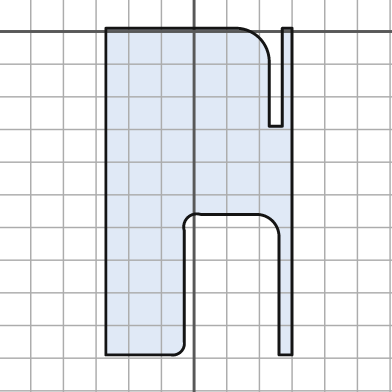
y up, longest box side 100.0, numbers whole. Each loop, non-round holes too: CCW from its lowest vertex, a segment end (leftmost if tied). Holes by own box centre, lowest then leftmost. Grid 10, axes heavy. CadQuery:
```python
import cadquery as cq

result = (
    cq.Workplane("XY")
    .moveTo(-27.0, -99.0)
    .lineTo(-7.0, -99.0)
    .threePointArc((-4.0, -98.0), (-3.0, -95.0))
    .lineTo(-3.0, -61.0)
    .threePointArc((-2.0, -57.0), (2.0, -56.0))
    .lineTo(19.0, -56.0)
    .threePointArc((24.0, -58.0), (26.0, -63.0))
    .lineTo(26.0, -99.0)
    .lineTo(30.0, -99.0)
    .lineTo(30.0, 1.0)
    .lineTo(27.0, 1.0)
    .lineTo(27.0, -29.0)
    .lineTo(23.0, -29.0)
    .lineTo(23.0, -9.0)
    .threePointArc((20.0, -2.0), (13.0, 1.0))
    .lineTo(-27.0, 1.0)
    .close()
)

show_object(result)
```